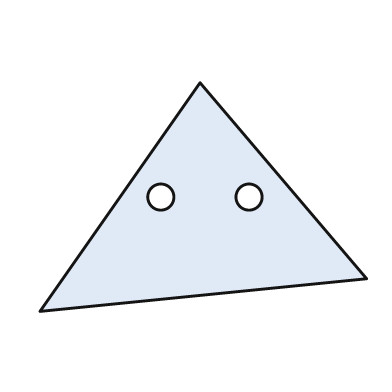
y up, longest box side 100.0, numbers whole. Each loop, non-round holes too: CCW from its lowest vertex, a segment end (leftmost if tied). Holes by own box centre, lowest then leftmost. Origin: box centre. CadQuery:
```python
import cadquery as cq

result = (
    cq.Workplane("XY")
    .moveTo(-50.0, -35.0)
    .lineTo(50.0, -25.0)
    .lineTo(-1.0, 35.0)
    .close()
    .moveTo(-13.0, 0.0)
    .circle(4.0)
    .moveTo(14.0, 0.0)
    .circle(4.0)
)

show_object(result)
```